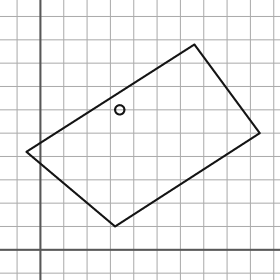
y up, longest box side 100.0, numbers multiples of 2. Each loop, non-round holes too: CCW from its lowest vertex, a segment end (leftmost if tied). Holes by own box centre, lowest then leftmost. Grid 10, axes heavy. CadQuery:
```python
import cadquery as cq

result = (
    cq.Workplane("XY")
    .moveTo(32.0, 10.0)
    .lineTo(94.0, 50.0)
    .lineTo(66.0, 88.0)
    .lineTo(-6.0, 42.0)
    .close()
    .moveTo(34.0, 60.0)
    .circle(2.0)
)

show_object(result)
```